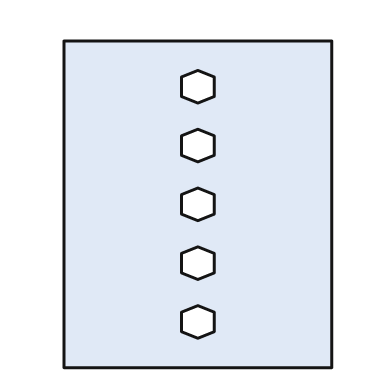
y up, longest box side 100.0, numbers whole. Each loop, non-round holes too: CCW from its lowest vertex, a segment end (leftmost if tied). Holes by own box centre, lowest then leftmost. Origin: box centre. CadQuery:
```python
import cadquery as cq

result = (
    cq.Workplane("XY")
    .moveTo(-41.0, -50.0)
    .lineTo(41.0, -50.0)
    .lineTo(41.0, 50.0)
    .lineTo(-41.0, 50.0)
    .close()
    .moveTo(0.0, -41.0)
    .lineTo(5.0, -39.0)
    .lineTo(5.0, -33.0)
    .lineTo(0.0, -31.0)
    .lineTo(-5.0, -33.0)
    .lineTo(-5.0, -39.0)
    .close()
    .moveTo(0.0, -23.0)
    .lineTo(5.0, -21.0)
    .lineTo(5.0, -15.0)
    .lineTo(0.0, -13.0)
    .lineTo(-5.0, -15.0)
    .lineTo(-5.0, -21.0)
    .close()
    .moveTo(0.0, -5.0)
    .lineTo(5.0, -3.0)
    .lineTo(5.0, 3.0)
    .lineTo(0.0, 5.0)
    .lineTo(-5.0, 3.0)
    .lineTo(-5.0, -3.0)
    .close()
    .moveTo(0.0, 13.0)
    .lineTo(5.0, 15.0)
    .lineTo(5.0, 21.0)
    .lineTo(0.0, 23.0)
    .lineTo(-5.0, 21.0)
    .lineTo(-5.0, 15.0)
    .close()
    .moveTo(0.0, 31.0)
    .lineTo(5.0, 33.0)
    .lineTo(5.0, 39.0)
    .lineTo(0.0, 41.0)
    .lineTo(-5.0, 39.0)
    .lineTo(-5.0, 33.0)
    .close()
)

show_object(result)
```